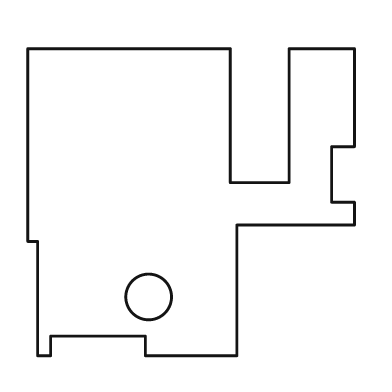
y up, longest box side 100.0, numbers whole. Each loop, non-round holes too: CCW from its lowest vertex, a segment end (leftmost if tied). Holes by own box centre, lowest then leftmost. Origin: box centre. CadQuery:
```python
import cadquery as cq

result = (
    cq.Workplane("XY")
    .moveTo(-47.0, -47.0)
    .lineTo(-43.0, -47.0)
    .lineTo(-43.0, -41.0)
    .lineTo(-14.0, -41.0)
    .lineTo(-14.0, -47.0)
    .lineTo(14.0, -47.0)
    .lineTo(14.0, -7.0)
    .lineTo(50.0, -7.0)
    .lineTo(50.0, 0.0)
    .lineTo(43.0, 0.0)
    .lineTo(43.0, 17.0)
    .lineTo(50.0, 17.0)
    .lineTo(50.0, 47.0)
    .lineTo(30.0, 47.0)
    .lineTo(30.0, 6.0)
    .lineTo(12.0, 6.0)
    .lineTo(12.0, 47.0)
    .lineTo(-50.0, 47.0)
    .lineTo(-50.0, -12.0)
    .lineTo(-47.0, -12.0)
    .close()
    .moveTo(-13.0, -29.0)
    .circle(7.0)
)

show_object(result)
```